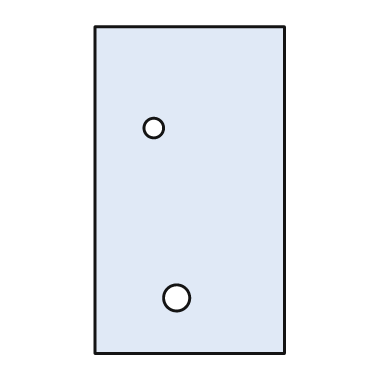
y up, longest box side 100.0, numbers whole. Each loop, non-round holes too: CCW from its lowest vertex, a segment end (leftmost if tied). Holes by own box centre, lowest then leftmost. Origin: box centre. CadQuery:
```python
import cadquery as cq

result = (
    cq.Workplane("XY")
    .moveTo(-29.0, -50.0)
    .lineTo(29.0, -50.0)
    .lineTo(29.0, 50.0)
    .lineTo(-29.0, 50.0)
    .close()
    .moveTo(-4.0, -33.0)
    .circle(4.0)
    .moveTo(-11.0, 19.0)
    .circle(3.0)
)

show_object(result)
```